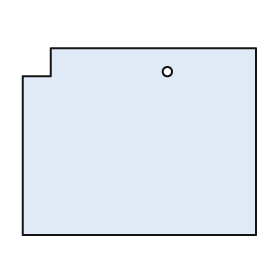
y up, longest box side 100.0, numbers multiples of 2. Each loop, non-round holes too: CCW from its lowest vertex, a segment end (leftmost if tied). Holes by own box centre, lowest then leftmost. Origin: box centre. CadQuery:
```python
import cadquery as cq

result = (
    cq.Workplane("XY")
    .moveTo(-50.0, -40.0)
    .lineTo(50.0, -40.0)
    .lineTo(50.0, 40.0)
    .lineTo(-38.0, 40.0)
    .lineTo(-38.0, 28.0)
    .lineTo(-50.0, 28.0)
    .close()
    .moveTo(12.0, 30.0)
    .circle(2.0)
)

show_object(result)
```